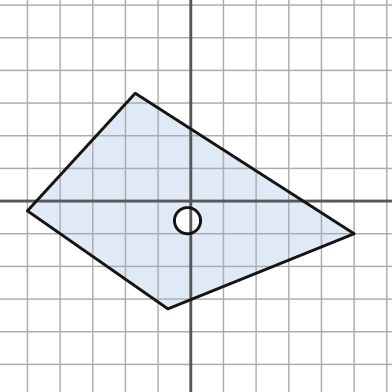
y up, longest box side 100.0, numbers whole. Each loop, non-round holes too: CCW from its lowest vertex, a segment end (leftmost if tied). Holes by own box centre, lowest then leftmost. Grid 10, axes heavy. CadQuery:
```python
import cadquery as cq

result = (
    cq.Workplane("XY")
    .moveTo(-7.0, -33.0)
    .lineTo(50.0, -10.0)
    .lineTo(-17.0, 33.0)
    .lineTo(-50.0, -3.0)
    .close()
    .moveTo(-1.0, -6.0)
    .circle(4.0)
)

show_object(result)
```